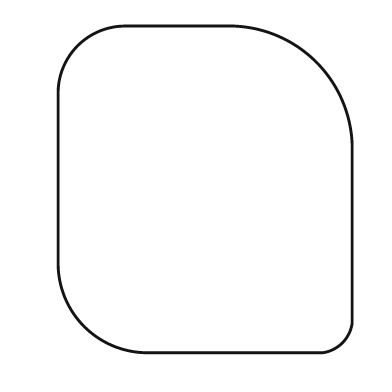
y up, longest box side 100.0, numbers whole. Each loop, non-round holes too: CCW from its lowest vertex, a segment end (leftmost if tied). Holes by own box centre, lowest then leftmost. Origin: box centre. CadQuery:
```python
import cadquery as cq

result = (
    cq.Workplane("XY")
    .moveTo(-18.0, -50.0)
    .lineTo(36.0, -50.0)
    .threePointArc((42.0, -47.0), (45.0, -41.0))
    .lineTo(45.0, 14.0)
    .threePointArc((34.0, 39.0), (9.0, 50.0))
    .lineTo(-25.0, 50.0)
    .threePointArc((-39.0, 44.0), (-45.0, 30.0))
    .lineTo(-45.0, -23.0)
    .threePointArc((-37.0, -42.0), (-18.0, -50.0))
    .close()
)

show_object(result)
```